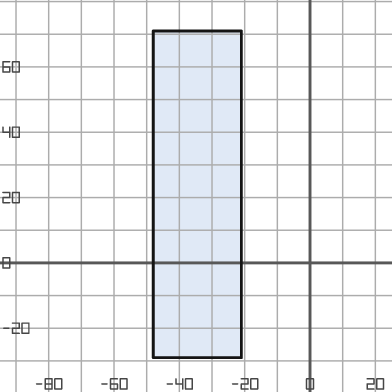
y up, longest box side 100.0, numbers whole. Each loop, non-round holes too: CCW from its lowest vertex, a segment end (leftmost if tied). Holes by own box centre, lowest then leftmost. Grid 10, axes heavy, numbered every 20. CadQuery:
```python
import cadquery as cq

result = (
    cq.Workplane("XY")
    .moveTo(-48.0, -29.0)
    .lineTo(-21.0, -29.0)
    .lineTo(-21.0, 71.0)
    .lineTo(-48.0, 71.0)
    .close()
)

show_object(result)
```